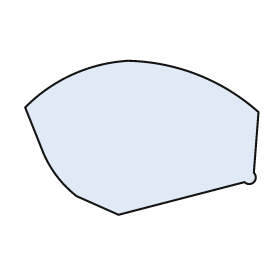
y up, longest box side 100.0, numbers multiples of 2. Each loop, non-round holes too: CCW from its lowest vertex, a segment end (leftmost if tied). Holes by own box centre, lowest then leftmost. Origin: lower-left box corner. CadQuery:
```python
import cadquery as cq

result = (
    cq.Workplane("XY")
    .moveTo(40.0, 0.0)
    .lineTo(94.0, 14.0)
    .threePointArc((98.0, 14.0), (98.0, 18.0))
    .lineTo(100.0, 44.0)
    .threePointArc((74.0, 60.0), (44.0, 66.0))
    .threePointArc((20.0, 60.0), (0.0, 46.0))
    .lineTo(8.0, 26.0)
    .threePointArc((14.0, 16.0), (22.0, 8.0))
    .close()
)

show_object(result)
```